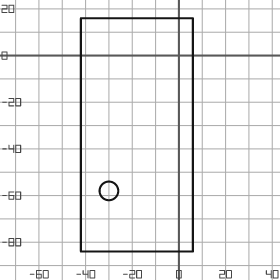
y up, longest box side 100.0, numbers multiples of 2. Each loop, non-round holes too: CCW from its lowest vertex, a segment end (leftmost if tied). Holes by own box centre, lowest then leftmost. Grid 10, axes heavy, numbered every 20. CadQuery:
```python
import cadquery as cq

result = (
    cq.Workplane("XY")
    .moveTo(-42.0, -84.0)
    .lineTo(6.0, -84.0)
    .lineTo(6.0, 16.0)
    .lineTo(-42.0, 16.0)
    .close()
    .moveTo(-30.0, -58.0)
    .circle(4.0)
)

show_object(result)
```